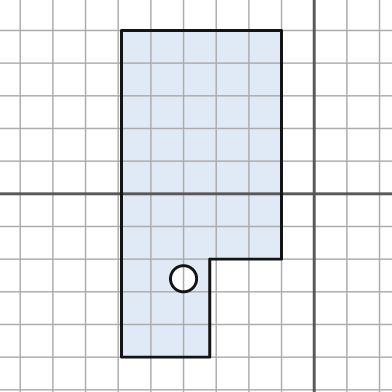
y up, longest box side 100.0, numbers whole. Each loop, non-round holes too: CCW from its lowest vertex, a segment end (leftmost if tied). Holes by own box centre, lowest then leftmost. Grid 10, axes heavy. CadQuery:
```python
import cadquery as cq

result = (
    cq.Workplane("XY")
    .moveTo(-59.0, -50.0)
    .lineTo(-32.0, -50.0)
    .lineTo(-32.0, -20.0)
    .lineTo(-10.0, -20.0)
    .lineTo(-10.0, 50.0)
    .lineTo(-59.0, 50.0)
    .close()
    .moveTo(-40.0, -26.0)
    .circle(4.0)
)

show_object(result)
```